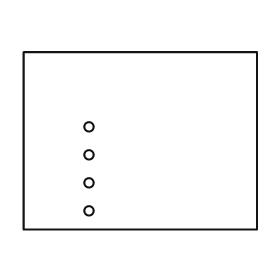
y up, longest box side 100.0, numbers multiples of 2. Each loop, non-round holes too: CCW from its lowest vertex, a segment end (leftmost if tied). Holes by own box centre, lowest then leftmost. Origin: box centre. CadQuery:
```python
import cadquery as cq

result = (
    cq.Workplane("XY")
    .moveTo(-50.0, -38.0)
    .lineTo(50.0, -38.0)
    .lineTo(50.0, 38.0)
    .lineTo(-50.0, 38.0)
    .close()
    .moveTo(-22.0, -30.0)
    .circle(2.0)
    .moveTo(-22.0, -18.0)
    .circle(2.0)
    .moveTo(-22.0, -6.0)
    .circle(2.0)
    .moveTo(-22.0, 6.0)
    .circle(2.0)
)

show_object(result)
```